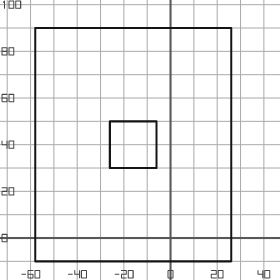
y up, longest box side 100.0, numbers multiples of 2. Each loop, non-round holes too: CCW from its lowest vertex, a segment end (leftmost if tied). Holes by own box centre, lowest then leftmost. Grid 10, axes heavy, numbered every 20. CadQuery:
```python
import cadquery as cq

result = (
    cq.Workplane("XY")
    .moveTo(-58.0, -10.0)
    .lineTo(26.0, -10.0)
    .lineTo(26.0, 90.0)
    .lineTo(-58.0, 90.0)
    .close()
    .moveTo(-26.0, 30.0)
    .lineTo(-6.0, 30.0)
    .lineTo(-6.0, 50.0)
    .lineTo(-26.0, 50.0)
    .close()
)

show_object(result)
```